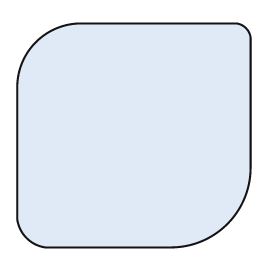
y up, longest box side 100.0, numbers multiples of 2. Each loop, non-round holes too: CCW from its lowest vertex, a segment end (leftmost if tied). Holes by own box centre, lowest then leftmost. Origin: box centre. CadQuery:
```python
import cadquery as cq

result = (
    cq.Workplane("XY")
    .moveTo(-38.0, -48.0)
    .lineTo(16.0, -48.0)
    .threePointArc((40.0, -38.0), (50.0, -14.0))
    .lineTo(50.0, 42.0)
    .threePointArc((48.0, 46.0), (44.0, 48.0))
    .lineTo(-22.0, 48.0)
    .threePointArc((-42.0, 40.0), (-50.0, 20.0))
    .lineTo(-50.0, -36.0)
    .threePointArc((-46.0, -44.0), (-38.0, -48.0))
    .close()
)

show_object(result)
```